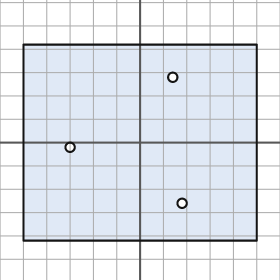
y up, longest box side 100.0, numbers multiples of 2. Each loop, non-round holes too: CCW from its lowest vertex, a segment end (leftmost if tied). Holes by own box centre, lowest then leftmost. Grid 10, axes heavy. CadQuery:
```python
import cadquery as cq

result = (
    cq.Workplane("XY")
    .moveTo(-50.0, -42.0)
    .lineTo(50.0, -42.0)
    .lineTo(50.0, 42.0)
    .lineTo(-50.0, 42.0)
    .close()
    .moveTo(18.0, -26.0)
    .circle(2.0)
    .moveTo(-30.0, -2.0)
    .circle(2.0)
    .moveTo(14.0, 28.0)
    .circle(2.0)
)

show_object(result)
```